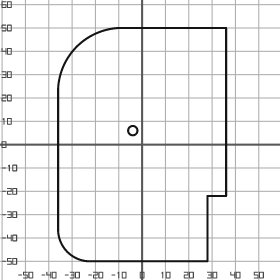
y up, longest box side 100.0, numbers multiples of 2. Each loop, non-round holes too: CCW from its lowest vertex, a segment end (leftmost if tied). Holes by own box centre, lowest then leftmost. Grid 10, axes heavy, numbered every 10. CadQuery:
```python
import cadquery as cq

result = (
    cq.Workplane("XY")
    .moveTo(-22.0, -50.0)
    .lineTo(28.0, -50.0)
    .lineTo(28.0, -22.0)
    .lineTo(36.0, -22.0)
    .lineTo(36.0, 50.0)
    .lineTo(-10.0, 50.0)
    .threePointArc((-28.0, 42.0), (-36.0, 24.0))
    .lineTo(-36.0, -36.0)
    .threePointArc((-32.0, -46.0), (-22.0, -50.0))
    .close()
    .moveTo(-4.0, 6.0)
    .circle(2.0)
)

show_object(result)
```